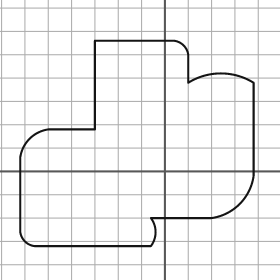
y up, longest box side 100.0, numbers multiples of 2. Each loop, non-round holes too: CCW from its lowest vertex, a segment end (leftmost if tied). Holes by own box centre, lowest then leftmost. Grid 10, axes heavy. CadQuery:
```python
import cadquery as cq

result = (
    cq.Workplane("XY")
    .moveTo(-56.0, -32.0)
    .lineTo(-6.0, -32.0)
    .threePointArc((-4.0, -26.0), (-6.0, -20.0))
    .lineTo(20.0, -20.0)
    .threePointArc((32.0, -14.0), (38.0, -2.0))
    .lineTo(38.0, 38.0)
    .threePointArc((24.0, 42.0), (10.0, 38.0))
    .lineTo(10.0, 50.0)
    .threePointArc((8.0, 54.0), (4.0, 56.0))
    .lineTo(-30.0, 56.0)
    .lineTo(-30.0, 18.0)
    .lineTo(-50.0, 18.0)
    .threePointArc((-58.0, 14.0), (-62.0, 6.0))
    .lineTo(-62.0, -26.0)
    .threePointArc((-60.0, -30.0), (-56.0, -32.0))
    .close()
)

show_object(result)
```